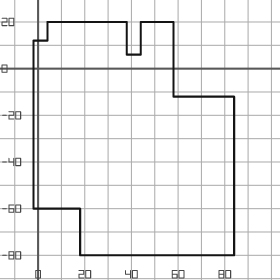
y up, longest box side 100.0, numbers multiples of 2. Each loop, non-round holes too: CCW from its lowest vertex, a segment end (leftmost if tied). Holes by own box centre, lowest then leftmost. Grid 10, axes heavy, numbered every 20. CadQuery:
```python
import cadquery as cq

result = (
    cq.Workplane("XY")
    .moveTo(18.0, -80.0)
    .lineTo(84.0, -80.0)
    .lineTo(84.0, -12.0)
    .lineTo(58.0, -12.0)
    .lineTo(58.0, 20.0)
    .lineTo(44.0, 20.0)
    .lineTo(44.0, 6.0)
    .lineTo(38.0, 6.0)
    .lineTo(38.0, 20.0)
    .lineTo(4.0, 20.0)
    .lineTo(4.0, 12.0)
    .lineTo(-2.0, 12.0)
    .lineTo(-2.0, -60.0)
    .lineTo(18.0, -60.0)
    .close()
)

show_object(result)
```